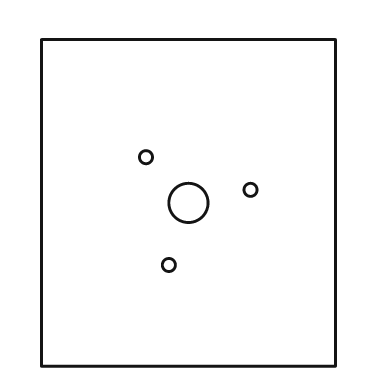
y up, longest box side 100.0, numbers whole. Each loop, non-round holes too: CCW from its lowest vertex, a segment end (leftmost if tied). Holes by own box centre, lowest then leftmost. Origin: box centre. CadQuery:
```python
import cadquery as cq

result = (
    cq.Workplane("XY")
    .moveTo(-45.0, -50.0)
    .lineTo(45.0, -50.0)
    .lineTo(45.0, 50.0)
    .lineTo(-45.0, 50.0)
    .close()
    .moveTo(-6.0, -19.0)
    .circle(2.0)
    .moveTo(0.0, 0.0)
    .circle(6.0)
    .moveTo(19.0, 4.0)
    .circle(2.0)
    .moveTo(-13.0, 14.0)
    .circle(2.0)
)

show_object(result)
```